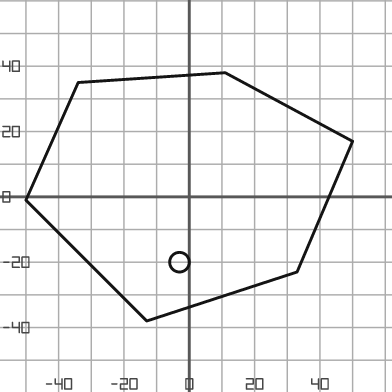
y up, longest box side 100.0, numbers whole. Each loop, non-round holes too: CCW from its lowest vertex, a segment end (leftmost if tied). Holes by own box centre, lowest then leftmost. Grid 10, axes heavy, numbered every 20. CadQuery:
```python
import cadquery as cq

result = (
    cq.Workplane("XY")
    .moveTo(-13.0, -38.0)
    .lineTo(33.0, -23.0)
    .lineTo(50.0, 17.0)
    .lineTo(11.0, 38.0)
    .lineTo(-34.0, 35.0)
    .lineTo(-50.0, -1.0)
    .close()
    .moveTo(-3.0, -20.0)
    .circle(3.0)
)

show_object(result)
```